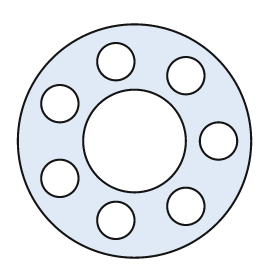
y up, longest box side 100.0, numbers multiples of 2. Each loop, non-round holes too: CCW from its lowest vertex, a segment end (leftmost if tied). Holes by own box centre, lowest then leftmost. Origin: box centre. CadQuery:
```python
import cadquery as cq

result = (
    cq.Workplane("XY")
    .moveTo(0.0, 0.0)
    .circle(50.0)
    .moveTo(-8.0, -34.0)
    .circle(8.0)
    .moveTo(22.0, -28.0)
    .circle(8.0)
    .moveTo(-32.0, -16.0)
    .circle(8.0)
    .moveTo(0.0, 0.0)
    .circle(22.0)
    .moveTo(36.0, 0.0)
    .circle(8.0)
    .moveTo(-32.0, 16.0)
    .circle(8.0)
    .moveTo(22.0, 28.0)
    .circle(8.0)
    .moveTo(-8.0, 34.0)
    .circle(8.0)
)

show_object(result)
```